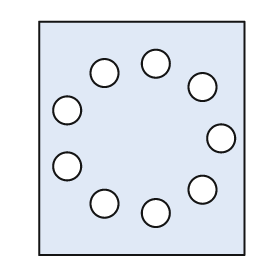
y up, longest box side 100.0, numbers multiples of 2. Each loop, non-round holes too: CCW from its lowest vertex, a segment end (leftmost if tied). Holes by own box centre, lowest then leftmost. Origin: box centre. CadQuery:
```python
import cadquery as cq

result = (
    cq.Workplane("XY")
    .moveTo(-44.0, -50.0)
    .lineTo(44.0, -50.0)
    .lineTo(44.0, 50.0)
    .lineTo(-44.0, 50.0)
    .close()
    .moveTo(6.0, -32.0)
    .circle(6.0)
    .moveTo(-16.0, -28.0)
    .circle(6.0)
    .moveTo(26.0, -22.0)
    .circle(6.0)
    .moveTo(-32.0, -12.0)
    .circle(6.0)
    .moveTo(34.0, 0.0)
    .circle(6.0)
    .moveTo(-32.0, 12.0)
    .circle(6.0)
    .moveTo(26.0, 22.0)
    .circle(6.0)
    .moveTo(-16.0, 28.0)
    .circle(6.0)
    .moveTo(6.0, 32.0)
    .circle(6.0)
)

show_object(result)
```